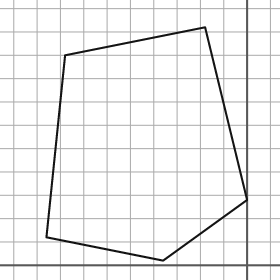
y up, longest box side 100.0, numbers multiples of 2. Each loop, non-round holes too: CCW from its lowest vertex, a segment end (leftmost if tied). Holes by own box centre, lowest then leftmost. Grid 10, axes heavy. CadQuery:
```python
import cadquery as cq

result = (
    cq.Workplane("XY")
    .moveTo(-36.0, 2.0)
    .lineTo(0.0, 28.0)
    .lineTo(-18.0, 102.0)
    .lineTo(-78.0, 90.0)
    .lineTo(-86.0, 12.0)
    .close()
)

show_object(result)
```